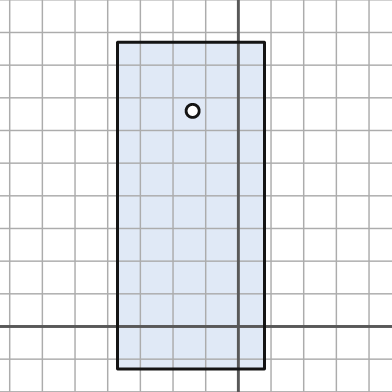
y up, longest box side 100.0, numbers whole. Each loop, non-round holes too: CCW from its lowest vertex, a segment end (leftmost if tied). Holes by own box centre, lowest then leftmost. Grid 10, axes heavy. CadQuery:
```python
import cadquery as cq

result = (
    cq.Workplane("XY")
    .moveTo(-37.0, -13.0)
    .lineTo(8.0, -13.0)
    .lineTo(8.0, 87.0)
    .lineTo(-37.0, 87.0)
    .close()
    .moveTo(-14.0, 66.0)
    .circle(2.0)
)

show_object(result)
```